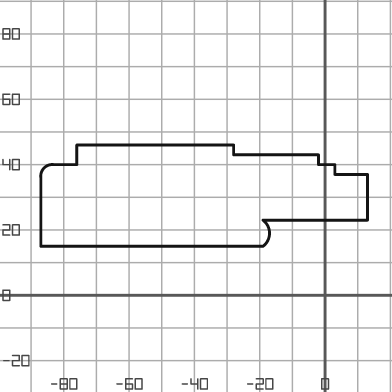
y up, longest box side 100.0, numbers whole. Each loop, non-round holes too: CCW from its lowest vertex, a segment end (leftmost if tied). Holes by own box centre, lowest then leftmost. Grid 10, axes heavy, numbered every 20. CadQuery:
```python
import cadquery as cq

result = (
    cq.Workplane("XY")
    .moveTo(-87.0, 15.0)
    .lineTo(-19.0, 15.0)
    .threePointArc((-17.0, 19.0), (-19.0, 23.0))
    .lineTo(13.0, 23.0)
    .lineTo(13.0, 37.0)
    .lineTo(3.0, 37.0)
    .lineTo(3.0, 40.0)
    .lineTo(-2.0, 40.0)
    .lineTo(-2.0, 43.0)
    .lineTo(-28.0, 43.0)
    .lineTo(-28.0, 46.0)
    .lineTo(-76.0, 46.0)
    .lineTo(-76.0, 40.0)
    .lineTo(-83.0, 40.0)
    .threePointArc((-86.0, 39.0), (-87.0, 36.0))
    .close()
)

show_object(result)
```